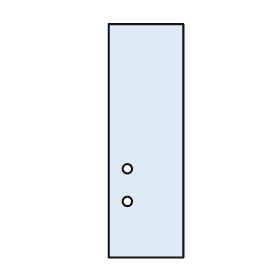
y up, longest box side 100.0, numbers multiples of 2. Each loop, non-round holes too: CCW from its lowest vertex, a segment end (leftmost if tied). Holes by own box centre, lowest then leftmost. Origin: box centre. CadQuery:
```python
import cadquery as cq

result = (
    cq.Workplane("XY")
    .moveTo(-16.0, -50.0)
    .lineTo(16.0, -50.0)
    .lineTo(16.0, 50.0)
    .lineTo(-16.0, 50.0)
    .close()
    .moveTo(-8.0, -26.0)
    .circle(2.0)
    .moveTo(-8.0, -12.0)
    .circle(2.0)
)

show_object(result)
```